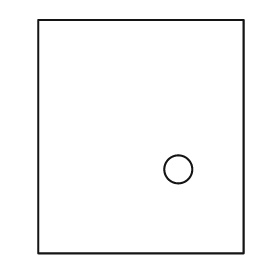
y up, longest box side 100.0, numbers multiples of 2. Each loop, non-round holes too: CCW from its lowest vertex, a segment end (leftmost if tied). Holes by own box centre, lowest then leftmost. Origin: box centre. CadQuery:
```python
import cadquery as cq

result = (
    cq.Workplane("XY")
    .moveTo(-44.0, -50.0)
    .lineTo(44.0, -50.0)
    .lineTo(44.0, 50.0)
    .lineTo(-44.0, 50.0)
    .close()
    .moveTo(16.0, -14.0)
    .circle(6.0)
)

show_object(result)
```